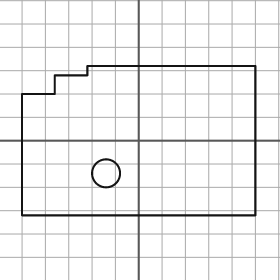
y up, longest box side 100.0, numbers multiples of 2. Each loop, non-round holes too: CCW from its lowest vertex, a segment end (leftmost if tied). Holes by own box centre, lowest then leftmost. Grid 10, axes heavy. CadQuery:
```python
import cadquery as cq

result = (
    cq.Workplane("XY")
    .moveTo(-50.0, -32.0)
    .lineTo(50.0, -32.0)
    .lineTo(50.0, 32.0)
    .lineTo(-22.0, 32.0)
    .lineTo(-22.0, 28.0)
    .lineTo(-36.0, 28.0)
    .lineTo(-36.0, 20.0)
    .lineTo(-50.0, 20.0)
    .close()
    .moveTo(-14.0, -14.0)
    .circle(6.0)
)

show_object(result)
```